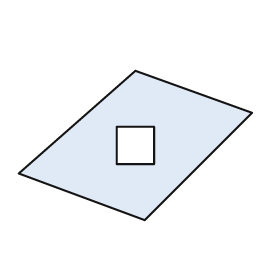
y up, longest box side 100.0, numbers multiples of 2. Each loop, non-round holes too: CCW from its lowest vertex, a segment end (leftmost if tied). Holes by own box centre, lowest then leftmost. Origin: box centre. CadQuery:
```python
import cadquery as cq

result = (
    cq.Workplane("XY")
    .moveTo(4.0, -32.0)
    .lineTo(50.0, 14.0)
    .lineTo(0.0, 32.0)
    .lineTo(-50.0, -12.0)
    .close()
    .moveTo(-8.0, -8.0)
    .lineTo(8.0, -8.0)
    .lineTo(8.0, 8.0)
    .lineTo(-8.0, 8.0)
    .close()
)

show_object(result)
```